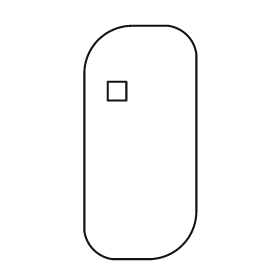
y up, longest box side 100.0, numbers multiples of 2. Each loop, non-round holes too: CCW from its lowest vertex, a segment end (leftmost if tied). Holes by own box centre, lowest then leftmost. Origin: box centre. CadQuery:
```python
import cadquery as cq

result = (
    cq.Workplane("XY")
    .moveTo(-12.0, -50.0)
    .lineTo(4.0, -50.0)
    .threePointArc((18.0, -44.0), (24.0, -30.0))
    .lineTo(24.0, 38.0)
    .threePointArc((20.0, 46.0), (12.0, 50.0))
    .lineTo(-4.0, 50.0)
    .threePointArc((-18.0, 44.0), (-24.0, 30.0))
    .lineTo(-24.0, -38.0)
    .threePointArc((-20.0, -46.0), (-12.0, -50.0))
    .close()
    .moveTo(-14.0, 18.0)
    .lineTo(-6.0, 18.0)
    .lineTo(-6.0, 26.0)
    .lineTo(-14.0, 26.0)
    .close()
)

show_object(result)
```